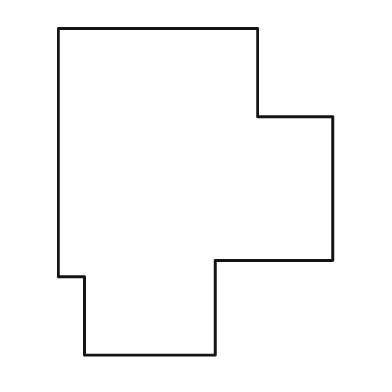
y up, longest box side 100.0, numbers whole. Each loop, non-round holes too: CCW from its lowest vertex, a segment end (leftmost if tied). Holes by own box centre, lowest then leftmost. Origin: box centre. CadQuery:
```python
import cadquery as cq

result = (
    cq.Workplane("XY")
    .moveTo(-34.0, -50.0)
    .lineTo(6.0, -50.0)
    .lineTo(6.0, -21.0)
    .lineTo(42.0, -21.0)
    .lineTo(42.0, 23.0)
    .lineTo(19.0, 23.0)
    .lineTo(19.0, 50.0)
    .lineTo(-42.0, 50.0)
    .lineTo(-42.0, -26.0)
    .lineTo(-34.0, -26.0)
    .close()
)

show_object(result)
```